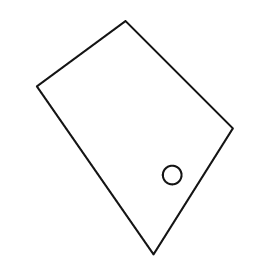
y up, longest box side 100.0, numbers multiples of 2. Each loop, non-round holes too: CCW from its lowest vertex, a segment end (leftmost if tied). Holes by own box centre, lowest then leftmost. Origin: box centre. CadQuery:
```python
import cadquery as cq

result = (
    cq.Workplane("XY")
    .moveTo(8.0, -50.0)
    .lineTo(42.0, 4.0)
    .lineTo(-4.0, 50.0)
    .lineTo(-42.0, 22.0)
    .close()
    .moveTo(16.0, -16.0)
    .circle(4.0)
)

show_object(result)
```